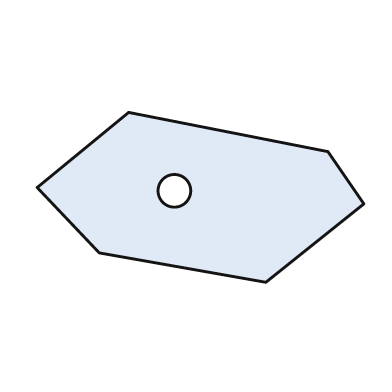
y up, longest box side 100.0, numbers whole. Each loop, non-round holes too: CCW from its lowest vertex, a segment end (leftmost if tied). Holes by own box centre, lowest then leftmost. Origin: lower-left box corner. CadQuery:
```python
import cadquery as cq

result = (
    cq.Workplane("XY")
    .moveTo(70.0, 0.0)
    .lineTo(100.0, 24.0)
    .lineTo(89.0, 40.0)
    .lineTo(28.0, 52.0)
    .lineTo(0.0, 29.0)
    .lineTo(19.0, 9.0)
    .close()
    .moveTo(42.0, 28.0)
    .circle(5.0)
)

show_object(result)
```